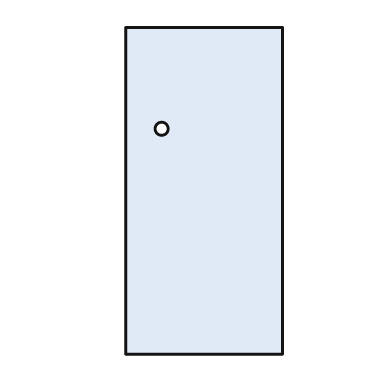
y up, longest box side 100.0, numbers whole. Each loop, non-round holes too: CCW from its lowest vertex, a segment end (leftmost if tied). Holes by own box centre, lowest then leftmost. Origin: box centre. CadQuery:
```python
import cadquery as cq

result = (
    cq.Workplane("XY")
    .moveTo(-24.0, -50.0)
    .lineTo(24.0, -50.0)
    .lineTo(24.0, 50.0)
    .lineTo(-24.0, 50.0)
    .close()
    .moveTo(-13.0, 19.0)
    .circle(2.0)
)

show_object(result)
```